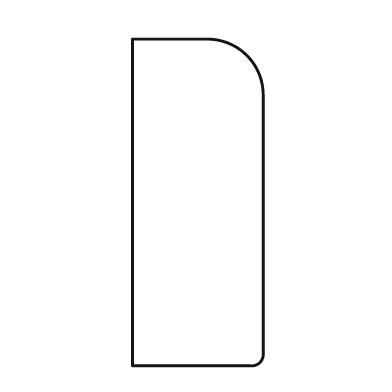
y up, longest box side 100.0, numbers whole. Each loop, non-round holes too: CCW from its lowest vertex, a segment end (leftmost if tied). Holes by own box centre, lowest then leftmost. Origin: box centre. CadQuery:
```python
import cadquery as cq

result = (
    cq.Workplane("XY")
    .moveTo(-20.0, -50.0)
    .lineTo(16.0, -50.0)
    .threePointArc((19.0, -49.0), (20.0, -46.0))
    .lineTo(20.0, 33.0)
    .threePointArc((15.0, 45.0), (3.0, 50.0))
    .lineTo(-20.0, 50.0)
    .close()
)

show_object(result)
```